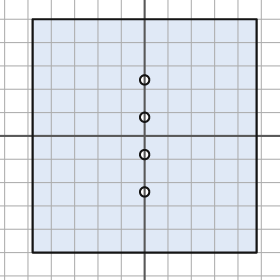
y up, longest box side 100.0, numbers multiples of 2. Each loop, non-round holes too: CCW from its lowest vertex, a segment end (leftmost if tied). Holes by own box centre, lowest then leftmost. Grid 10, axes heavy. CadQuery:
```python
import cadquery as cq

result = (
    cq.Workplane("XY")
    .moveTo(-48.0, -50.0)
    .lineTo(48.0, -50.0)
    .lineTo(48.0, 50.0)
    .lineTo(-48.0, 50.0)
    .close()
    .moveTo(0.0, -24.0)
    .circle(2.0)
    .moveTo(0.0, -8.0)
    .circle(2.0)
    .moveTo(0.0, 8.0)
    .circle(2.0)
    .moveTo(0.0, 24.0)
    .circle(2.0)
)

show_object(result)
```